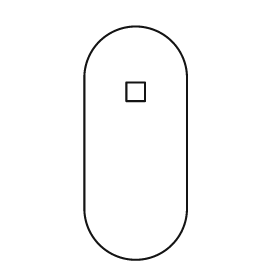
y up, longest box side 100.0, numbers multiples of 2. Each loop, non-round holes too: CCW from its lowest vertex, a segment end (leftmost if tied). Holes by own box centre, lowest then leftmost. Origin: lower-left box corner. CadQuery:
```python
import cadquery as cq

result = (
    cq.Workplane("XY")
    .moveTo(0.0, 22.0)
    .threePointArc((22.0, 0.0), (44.0, 22.0))
    .lineTo(44.0, 78.0)
    .threePointArc((22.0, 100.0), (0.0, 78.0))
    .close()
    .moveTo(18.0, 68.0)
    .lineTo(26.0, 68.0)
    .lineTo(26.0, 76.0)
    .lineTo(18.0, 76.0)
    .close()
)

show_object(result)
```